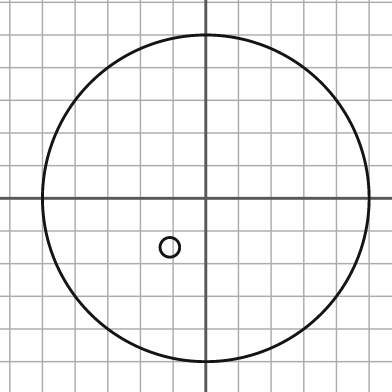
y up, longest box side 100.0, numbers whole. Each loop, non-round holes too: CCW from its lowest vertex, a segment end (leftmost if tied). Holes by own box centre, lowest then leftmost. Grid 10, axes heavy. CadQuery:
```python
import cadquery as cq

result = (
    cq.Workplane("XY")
    .moveTo(0.0, 0.0)
    .circle(50.0)
    .moveTo(-11.0, -15.0)
    .circle(3.0)
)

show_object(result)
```